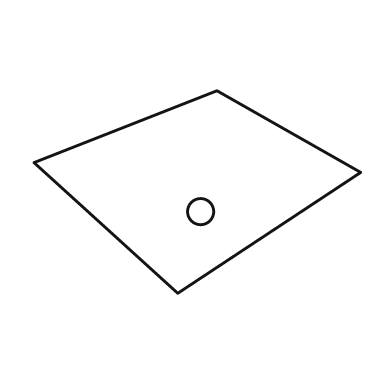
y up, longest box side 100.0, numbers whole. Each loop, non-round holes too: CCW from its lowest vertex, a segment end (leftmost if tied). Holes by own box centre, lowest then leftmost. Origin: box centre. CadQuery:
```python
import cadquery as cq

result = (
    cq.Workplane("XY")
    .moveTo(-6.0, -31.0)
    .lineTo(50.0, 6.0)
    .lineTo(6.0, 31.0)
    .lineTo(-50.0, 9.0)
    .close()
    .moveTo(1.0, -6.0)
    .circle(4.0)
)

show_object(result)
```